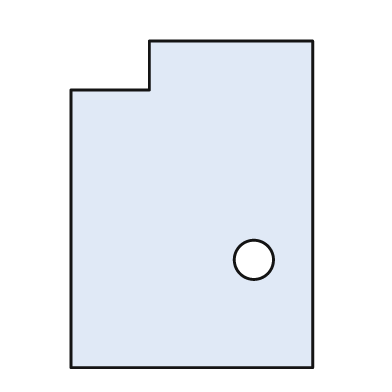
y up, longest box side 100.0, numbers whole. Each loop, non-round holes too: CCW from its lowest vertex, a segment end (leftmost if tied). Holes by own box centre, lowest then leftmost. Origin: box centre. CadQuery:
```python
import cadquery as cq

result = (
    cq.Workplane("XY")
    .moveTo(-37.0, -50.0)
    .lineTo(37.0, -50.0)
    .lineTo(37.0, 50.0)
    .lineTo(-13.0, 50.0)
    .lineTo(-13.0, 35.0)
    .lineTo(-37.0, 35.0)
    .close()
    .moveTo(19.0, -17.0)
    .circle(6.0)
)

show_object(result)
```